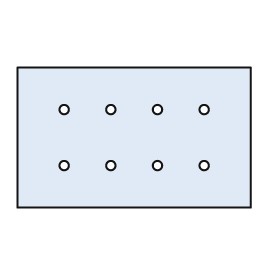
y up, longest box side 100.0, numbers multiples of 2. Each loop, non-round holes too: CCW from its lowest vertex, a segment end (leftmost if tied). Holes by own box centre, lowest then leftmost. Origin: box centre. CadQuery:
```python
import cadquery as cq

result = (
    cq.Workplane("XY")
    .moveTo(-50.0, -30.0)
    .lineTo(50.0, -30.0)
    .lineTo(50.0, 30.0)
    .lineTo(-50.0, 30.0)
    .close()
    .moveTo(-30.0, -12.0)
    .circle(2.0)
    .moveTo(-10.0, -12.0)
    .circle(2.0)
    .moveTo(10.0, -12.0)
    .circle(2.0)
    .moveTo(30.0, -12.0)
    .circle(2.0)
    .moveTo(-30.0, 12.0)
    .circle(2.0)
    .moveTo(-10.0, 12.0)
    .circle(2.0)
    .moveTo(10.0, 12.0)
    .circle(2.0)
    .moveTo(30.0, 12.0)
    .circle(2.0)
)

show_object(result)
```